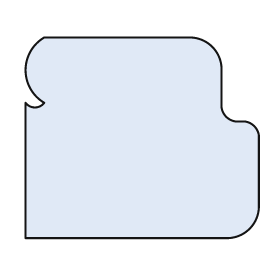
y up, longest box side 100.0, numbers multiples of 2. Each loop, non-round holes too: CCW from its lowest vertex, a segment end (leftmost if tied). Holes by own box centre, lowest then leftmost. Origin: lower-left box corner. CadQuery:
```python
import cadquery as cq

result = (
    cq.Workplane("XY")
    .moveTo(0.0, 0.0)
    .lineTo(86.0, 0.0)
    .threePointArc((96.0, 4.0), (100.0, 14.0))
    .lineTo(100.0, 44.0)
    .threePointArc((98.0, 48.0), (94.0, 50.0))
    .lineTo(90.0, 50.0)
    .threePointArc((86.0, 52.0), (84.0, 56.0))
    .lineTo(84.0, 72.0)
    .threePointArc((80.0, 82.0), (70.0, 86.0))
    .lineTo(8.0, 86.0)
    .threePointArc((0.0, 72.0), (8.0, 58.0))
    .threePointArc((4.0, 56.0), (0.0, 58.0))
    .close()
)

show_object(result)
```